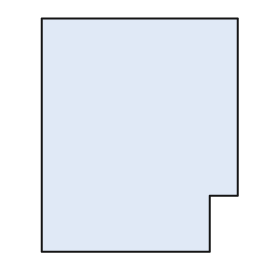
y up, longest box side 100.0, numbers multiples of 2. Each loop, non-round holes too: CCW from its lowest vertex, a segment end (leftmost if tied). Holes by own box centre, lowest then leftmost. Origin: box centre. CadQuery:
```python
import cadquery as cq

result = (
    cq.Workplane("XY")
    .moveTo(-42.0, -50.0)
    .lineTo(30.0, -50.0)
    .lineTo(30.0, -26.0)
    .lineTo(42.0, -26.0)
    .lineTo(42.0, 50.0)
    .lineTo(-42.0, 50.0)
    .close()
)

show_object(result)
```